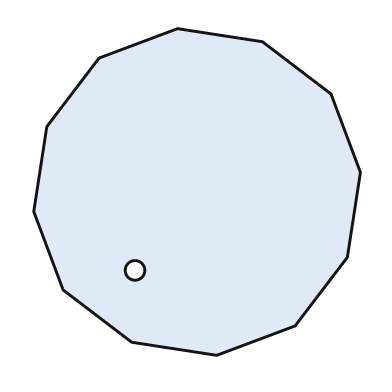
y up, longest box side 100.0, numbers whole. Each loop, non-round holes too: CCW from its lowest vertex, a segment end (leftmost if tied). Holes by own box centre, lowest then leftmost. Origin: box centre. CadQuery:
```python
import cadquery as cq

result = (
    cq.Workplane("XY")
    .moveTo(6.0, -50.0)
    .lineTo(30.0, -41.0)
    .lineTo(46.0, -20.0)
    .lineTo(50.0, 6.0)
    .lineTo(41.0, 30.0)
    .lineTo(20.0, 46.0)
    .lineTo(-6.0, 50.0)
    .lineTo(-30.0, 41.0)
    .lineTo(-46.0, 20.0)
    .lineTo(-50.0, -6.0)
    .lineTo(-41.0, -30.0)
    .lineTo(-20.0, -46.0)
    .close()
    .moveTo(-19.0, -24.0)
    .circle(3.0)
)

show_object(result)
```